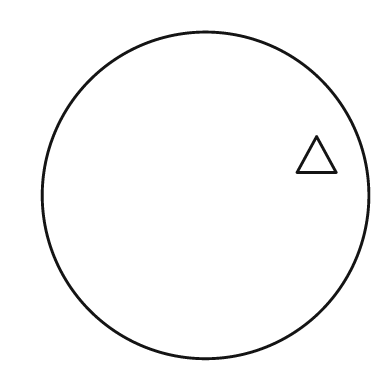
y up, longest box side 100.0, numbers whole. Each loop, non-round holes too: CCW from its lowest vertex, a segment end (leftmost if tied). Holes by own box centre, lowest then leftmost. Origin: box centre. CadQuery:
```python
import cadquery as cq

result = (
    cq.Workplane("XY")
    .moveTo(0.0, 0.0)
    .circle(50.0)
    .moveTo(28.0, 7.0)
    .lineTo(40.0, 7.0)
    .lineTo(34.0, 18.0)
    .close()
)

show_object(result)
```